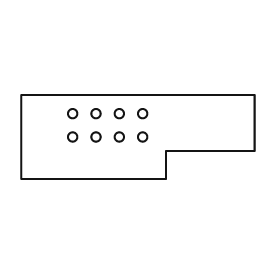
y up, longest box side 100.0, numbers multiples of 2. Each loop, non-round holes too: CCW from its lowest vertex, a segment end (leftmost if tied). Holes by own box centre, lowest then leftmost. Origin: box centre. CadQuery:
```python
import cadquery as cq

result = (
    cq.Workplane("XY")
    .moveTo(-50.0, -18.0)
    .lineTo(12.0, -18.0)
    .lineTo(12.0, -6.0)
    .lineTo(50.0, -6.0)
    .lineTo(50.0, 18.0)
    .lineTo(-50.0, 18.0)
    .close()
    .moveTo(-28.0, 0.0)
    .circle(2.0)
    .moveTo(-18.0, 0.0)
    .circle(2.0)
    .moveTo(-8.0, 0.0)
    .circle(2.0)
    .moveTo(2.0, 0.0)
    .circle(2.0)
    .moveTo(-28.0, 10.0)
    .circle(2.0)
    .moveTo(-18.0, 10.0)
    .circle(2.0)
    .moveTo(-8.0, 10.0)
    .circle(2.0)
    .moveTo(2.0, 10.0)
    .circle(2.0)
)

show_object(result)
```